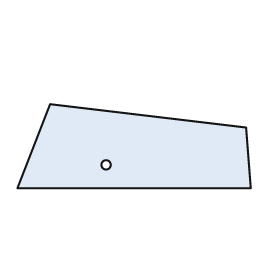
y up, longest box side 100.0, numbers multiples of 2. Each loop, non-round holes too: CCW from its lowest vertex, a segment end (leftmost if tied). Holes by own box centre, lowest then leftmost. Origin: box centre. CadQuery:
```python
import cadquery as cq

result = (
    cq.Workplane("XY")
    .moveTo(-50.0, -18.0)
    .lineTo(50.0, -18.0)
    .lineTo(48.0, 8.0)
    .lineTo(-36.0, 18.0)
    .close()
    .moveTo(-12.0, -8.0)
    .circle(2.0)
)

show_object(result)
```